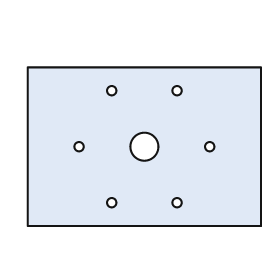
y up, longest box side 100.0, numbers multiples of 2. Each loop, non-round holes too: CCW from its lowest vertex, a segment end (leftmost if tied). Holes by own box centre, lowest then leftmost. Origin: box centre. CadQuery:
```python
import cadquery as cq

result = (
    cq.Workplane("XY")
    .moveTo(-50.0, -34.0)
    .lineTo(50.0, -34.0)
    .lineTo(50.0, 34.0)
    .lineTo(-50.0, 34.0)
    .close()
    .moveTo(-14.0, -24.0)
    .circle(2.0)
    .moveTo(14.0, -24.0)
    .circle(2.0)
    .moveTo(-28.0, 0.0)
    .circle(2.0)
    .moveTo(0.0, 0.0)
    .circle(6.0)
    .moveTo(28.0, 0.0)
    .circle(2.0)
    .moveTo(-14.0, 24.0)
    .circle(2.0)
    .moveTo(14.0, 24.0)
    .circle(2.0)
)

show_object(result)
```